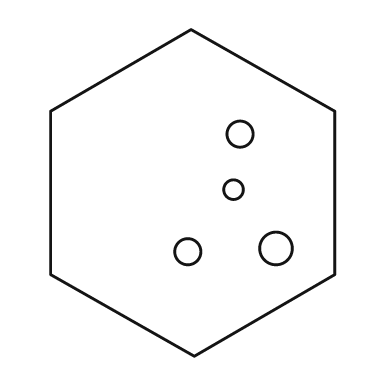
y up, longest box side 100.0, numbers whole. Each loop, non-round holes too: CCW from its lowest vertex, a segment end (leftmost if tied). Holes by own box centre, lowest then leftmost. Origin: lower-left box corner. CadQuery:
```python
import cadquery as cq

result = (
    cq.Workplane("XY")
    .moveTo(44.0, 0.0)
    .lineTo(87.0, 25.0)
    .lineTo(87.0, 75.0)
    .lineTo(43.0, 100.0)
    .lineTo(0.0, 75.0)
    .lineTo(0.0, 25.0)
    .close()
    .moveTo(42.0, 32.0)
    .circle(4.0)
    .moveTo(69.0, 33.0)
    .circle(5.0)
    .moveTo(56.0, 51.0)
    .circle(3.0)
    .moveTo(58.0, 68.0)
    .circle(4.0)
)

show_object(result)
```